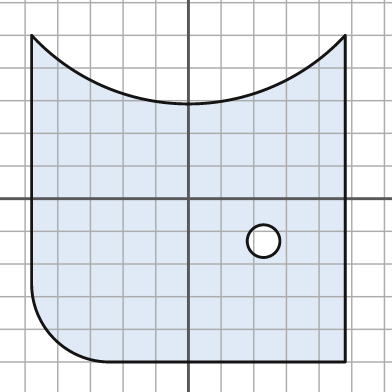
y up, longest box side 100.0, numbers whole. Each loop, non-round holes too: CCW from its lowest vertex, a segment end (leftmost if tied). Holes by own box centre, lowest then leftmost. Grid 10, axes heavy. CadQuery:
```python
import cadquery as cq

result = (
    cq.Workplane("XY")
    .moveTo(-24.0, -50.0)
    .lineTo(48.0, -50.0)
    .lineTo(48.0, 50.0)
    .threePointArc((0.0, 29.0), (-48.0, 50.0))
    .lineTo(-48.0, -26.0)
    .threePointArc((-41.0, -43.0), (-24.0, -50.0))
    .close()
    .moveTo(23.0, -13.0)
    .circle(5.0)
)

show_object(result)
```